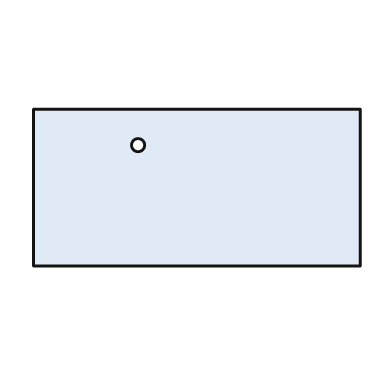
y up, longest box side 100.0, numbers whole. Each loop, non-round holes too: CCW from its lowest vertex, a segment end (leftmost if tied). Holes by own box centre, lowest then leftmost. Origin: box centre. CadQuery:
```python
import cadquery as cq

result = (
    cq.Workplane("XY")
    .moveTo(-50.0, -24.0)
    .lineTo(50.0, -24.0)
    .lineTo(50.0, 24.0)
    .lineTo(-50.0, 24.0)
    .close()
    .moveTo(-18.0, 13.0)
    .circle(2.0)
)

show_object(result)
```